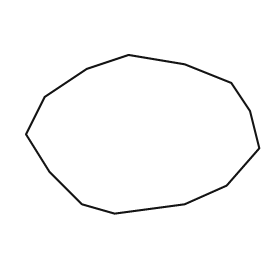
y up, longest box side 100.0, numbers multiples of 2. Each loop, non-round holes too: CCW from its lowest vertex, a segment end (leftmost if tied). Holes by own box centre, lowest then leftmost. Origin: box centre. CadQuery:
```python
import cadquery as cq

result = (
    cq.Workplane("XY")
    .moveTo(-12.0, -34.0)
    .lineTo(18.0, -30.0)
    .lineTo(36.0, -22.0)
    .lineTo(50.0, -6.0)
    .lineTo(46.0, 10.0)
    .lineTo(38.0, 22.0)
    .lineTo(18.0, 30.0)
    .lineTo(-6.0, 34.0)
    .lineTo(-24.0, 28.0)
    .lineTo(-42.0, 16.0)
    .lineTo(-50.0, 0.0)
    .lineTo(-40.0, -16.0)
    .lineTo(-26.0, -30.0)
    .close()
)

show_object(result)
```